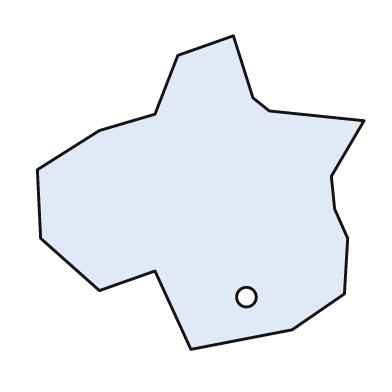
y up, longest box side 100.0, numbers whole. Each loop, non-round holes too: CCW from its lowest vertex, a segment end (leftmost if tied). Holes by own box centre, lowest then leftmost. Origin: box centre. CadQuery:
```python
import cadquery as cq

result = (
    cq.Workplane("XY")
    .moveTo(-3.0, -48.0)
    .lineTo(28.0, -42.0)
    .lineTo(44.0, -31.0)
    .lineTo(45.0, -14.0)
    .lineTo(41.0, -5.0)
    .lineTo(40.0, 5.0)
    .lineTo(50.0, 22.0)
    .lineTo(21.0, 25.0)
    .lineTo(16.0, 29.0)
    .lineTo(10.0, 48.0)
    .lineTo(-7.0, 42.0)
    .lineTo(-14.0, 24.0)
    .lineTo(-31.0, 19.0)
    .lineTo(-50.0, 7.0)
    .lineTo(-49.0, -14.0)
    .lineTo(-31.0, -30.0)
    .lineTo(-14.0, -24.0)
    .close()
    .moveTo(14.0, -32.0)
    .circle(3.0)
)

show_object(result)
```